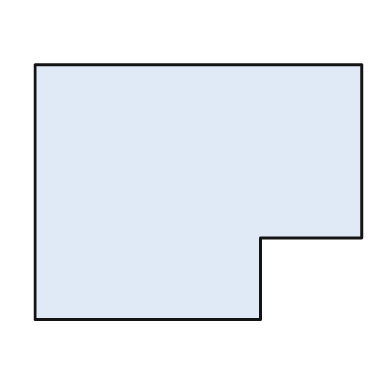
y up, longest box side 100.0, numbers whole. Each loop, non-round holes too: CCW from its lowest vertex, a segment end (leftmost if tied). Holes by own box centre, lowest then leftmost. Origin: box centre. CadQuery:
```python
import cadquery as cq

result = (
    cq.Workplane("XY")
    .moveTo(-50.0, -39.0)
    .lineTo(19.0, -39.0)
    .lineTo(19.0, -14.0)
    .lineTo(50.0, -14.0)
    .lineTo(50.0, 39.0)
    .lineTo(-50.0, 39.0)
    .close()
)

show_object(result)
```